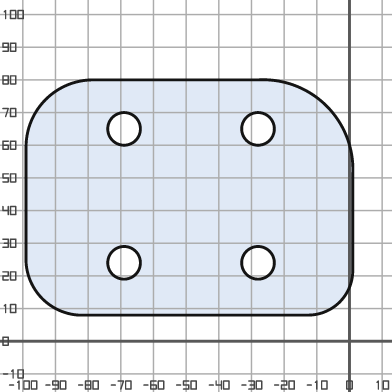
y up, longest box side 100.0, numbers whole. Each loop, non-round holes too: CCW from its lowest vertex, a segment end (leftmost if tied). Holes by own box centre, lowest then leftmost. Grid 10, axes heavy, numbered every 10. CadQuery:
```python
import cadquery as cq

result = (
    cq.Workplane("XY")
    .moveTo(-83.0, 8.0)
    .lineTo(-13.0, 8.0)
    .threePointArc((-3.0, 12.0), (1.0, 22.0))
    .lineTo(1.0, 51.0)
    .threePointArc((-7.0, 72.0), (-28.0, 80.0))
    .lineTo(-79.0, 80.0)
    .threePointArc((-93.0, 74.0), (-99.0, 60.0))
    .lineTo(-99.0, 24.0)
    .threePointArc((-94.0, 13.0), (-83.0, 8.0))
    .close()
    .moveTo(-69.0, 24.0)
    .circle(5.0)
    .moveTo(-28.0, 24.0)
    .circle(5.0)
    .moveTo(-69.0, 65.0)
    .circle(5.0)
    .moveTo(-28.0, 65.0)
    .circle(5.0)
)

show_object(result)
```